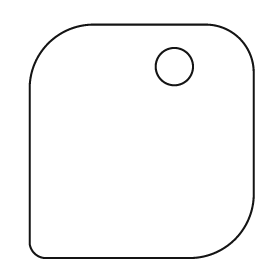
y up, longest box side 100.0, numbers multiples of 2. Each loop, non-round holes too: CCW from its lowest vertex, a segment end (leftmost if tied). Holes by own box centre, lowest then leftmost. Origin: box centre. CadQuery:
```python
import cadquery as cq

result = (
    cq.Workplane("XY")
    .moveTo(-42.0, -50.0)
    .lineTo(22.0, -50.0)
    .threePointArc((40.0, -42.0), (48.0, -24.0))
    .lineTo(48.0, 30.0)
    .threePointArc((42.0, 44.0), (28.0, 50.0))
    .lineTo(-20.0, 50.0)
    .threePointArc((-40.0, 42.0), (-48.0, 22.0))
    .lineTo(-48.0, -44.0)
    .threePointArc((-46.0, -48.0), (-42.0, -50.0))
    .close()
    .moveTo(14.0, 32.0)
    .circle(8.0)
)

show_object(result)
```